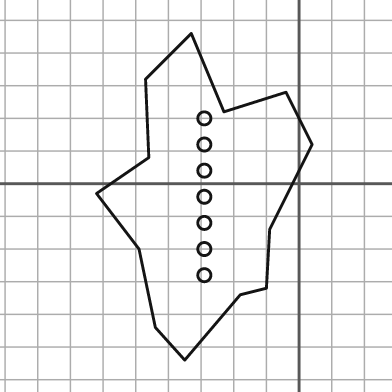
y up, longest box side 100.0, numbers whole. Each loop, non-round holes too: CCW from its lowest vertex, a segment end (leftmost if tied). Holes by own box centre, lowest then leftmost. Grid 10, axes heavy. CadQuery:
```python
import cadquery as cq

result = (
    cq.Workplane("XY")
    .moveTo(-35.0, -54.0)
    .lineTo(-18.0, -34.0)
    .lineTo(-10.0, -32.0)
    .lineTo(-9.0, -14.0)
    .lineTo(4.0, 12.0)
    .lineTo(-4.0, 28.0)
    .lineTo(-23.0, 22.0)
    .lineTo(-33.0, 46.0)
    .lineTo(-47.0, 32.0)
    .lineTo(-46.0, 8.0)
    .lineTo(-62.0, -3.0)
    .lineTo(-49.0, -20.0)
    .lineTo(-44.0, -44.0)
    .close()
    .moveTo(-29.0, -28.0)
    .circle(2.0)
    .moveTo(-29.0, -20.0)
    .circle(2.0)
    .moveTo(-29.0, -12.0)
    .circle(2.0)
    .moveTo(-29.0, -4.0)
    .circle(2.0)
    .moveTo(-29.0, 4.0)
    .circle(2.0)
    .moveTo(-29.0, 12.0)
    .circle(2.0)
    .moveTo(-29.0, 20.0)
    .circle(2.0)
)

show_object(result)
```